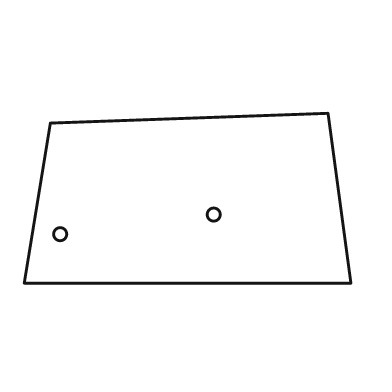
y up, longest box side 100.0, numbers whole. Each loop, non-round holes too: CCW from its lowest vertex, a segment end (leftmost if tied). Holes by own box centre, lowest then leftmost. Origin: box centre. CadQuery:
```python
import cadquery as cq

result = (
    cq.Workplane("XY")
    .moveTo(-50.0, -26.0)
    .lineTo(50.0, -26.0)
    .lineTo(43.0, 26.0)
    .lineTo(-42.0, 23.0)
    .close()
    .moveTo(-39.0, -11.0)
    .circle(2.0)
    .moveTo(8.0, -5.0)
    .circle(2.0)
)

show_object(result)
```